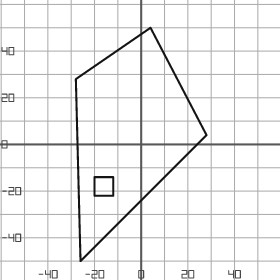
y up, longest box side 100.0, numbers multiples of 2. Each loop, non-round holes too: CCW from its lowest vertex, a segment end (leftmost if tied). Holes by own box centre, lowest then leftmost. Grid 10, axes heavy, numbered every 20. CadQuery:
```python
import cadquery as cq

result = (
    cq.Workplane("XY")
    .moveTo(-26.0, -50.0)
    .lineTo(28.0, 4.0)
    .lineTo(4.0, 50.0)
    .lineTo(-28.0, 28.0)
    .close()
    .moveTo(-20.0, -22.0)
    .lineTo(-12.0, -22.0)
    .lineTo(-12.0, -14.0)
    .lineTo(-20.0, -14.0)
    .close()
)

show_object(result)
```